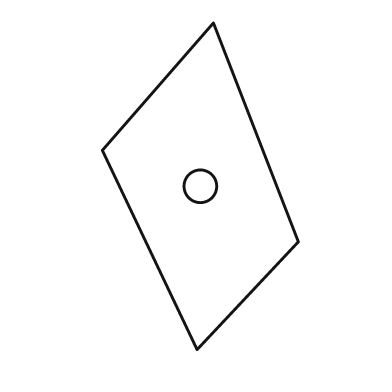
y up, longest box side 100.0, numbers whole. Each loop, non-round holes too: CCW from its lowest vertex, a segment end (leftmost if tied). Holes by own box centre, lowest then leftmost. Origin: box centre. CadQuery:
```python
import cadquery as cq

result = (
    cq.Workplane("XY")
    .moveTo(-1.0, -50.0)
    .lineTo(30.0, -17.0)
    .lineTo(4.0, 50.0)
    .lineTo(-30.0, 11.0)
    .close()
    .moveTo(0.0, 0.0)
    .circle(5.0)
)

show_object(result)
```